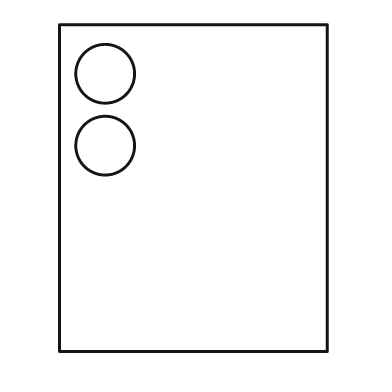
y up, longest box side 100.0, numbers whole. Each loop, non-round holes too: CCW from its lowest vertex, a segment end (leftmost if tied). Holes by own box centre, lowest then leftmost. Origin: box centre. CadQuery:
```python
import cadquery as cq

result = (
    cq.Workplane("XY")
    .moveTo(-41.0, -50.0)
    .lineTo(41.0, -50.0)
    .lineTo(41.0, 50.0)
    .lineTo(-41.0, 50.0)
    .close()
    .moveTo(-27.0, 13.0)
    .circle(9.0)
    .moveTo(-27.0, 35.0)
    .circle(9.0)
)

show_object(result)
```